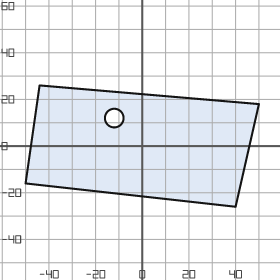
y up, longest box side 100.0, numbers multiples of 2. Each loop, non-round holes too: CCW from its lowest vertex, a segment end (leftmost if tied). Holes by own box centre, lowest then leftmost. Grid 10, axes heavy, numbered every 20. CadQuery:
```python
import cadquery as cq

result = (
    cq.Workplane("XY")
    .moveTo(40.0, -26.0)
    .lineTo(50.0, 18.0)
    .lineTo(-44.0, 26.0)
    .lineTo(-50.0, -16.0)
    .close()
    .moveTo(-12.0, 12.0)
    .circle(4.0)
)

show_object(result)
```